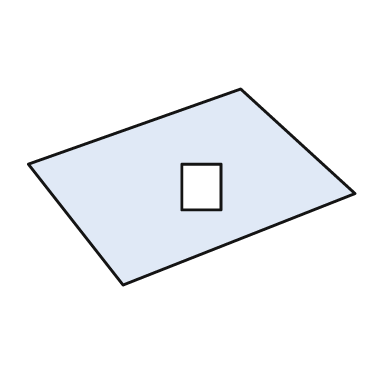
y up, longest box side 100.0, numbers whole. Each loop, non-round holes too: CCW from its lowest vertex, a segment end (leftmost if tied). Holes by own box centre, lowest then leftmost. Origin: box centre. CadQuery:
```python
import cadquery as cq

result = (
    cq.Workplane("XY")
    .moveTo(-21.0, -30.0)
    .lineTo(50.0, -2.0)
    .lineTo(15.0, 30.0)
    .lineTo(-50.0, 7.0)
    .close()
    .moveTo(-3.0, -7.0)
    .lineTo(9.0, -7.0)
    .lineTo(9.0, 7.0)
    .lineTo(-3.0, 7.0)
    .close()
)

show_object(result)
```